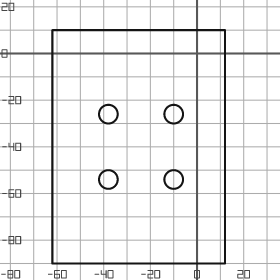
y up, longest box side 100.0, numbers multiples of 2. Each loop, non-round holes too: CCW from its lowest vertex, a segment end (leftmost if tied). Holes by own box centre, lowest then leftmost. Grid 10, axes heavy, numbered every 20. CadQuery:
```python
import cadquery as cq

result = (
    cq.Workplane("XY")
    .moveTo(-62.0, -90.0)
    .lineTo(12.0, -90.0)
    .lineTo(12.0, 10.0)
    .lineTo(-62.0, 10.0)
    .close()
    .moveTo(-38.0, -54.0)
    .circle(4.0)
    .moveTo(-10.0, -54.0)
    .circle(4.0)
    .moveTo(-38.0, -26.0)
    .circle(4.0)
    .moveTo(-10.0, -26.0)
    .circle(4.0)
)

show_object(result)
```